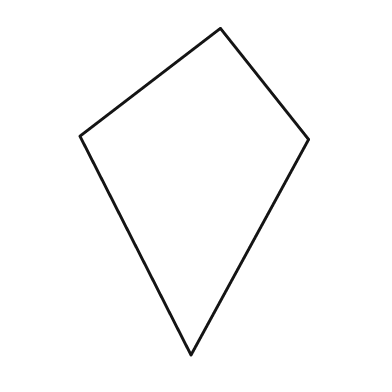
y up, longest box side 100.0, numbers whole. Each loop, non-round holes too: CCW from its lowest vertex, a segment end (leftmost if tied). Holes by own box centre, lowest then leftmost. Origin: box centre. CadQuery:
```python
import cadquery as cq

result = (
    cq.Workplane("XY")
    .moveTo(-1.0, -50.0)
    .lineTo(35.0, 16.0)
    .lineTo(8.0, 50.0)
    .lineTo(-35.0, 17.0)
    .close()
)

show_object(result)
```